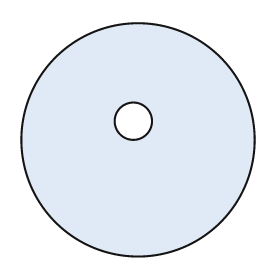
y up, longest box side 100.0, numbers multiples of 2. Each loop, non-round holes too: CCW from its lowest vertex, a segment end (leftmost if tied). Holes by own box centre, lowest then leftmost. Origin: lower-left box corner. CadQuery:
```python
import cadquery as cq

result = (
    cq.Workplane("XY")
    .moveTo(50.0, 50.0)
    .circle(50.0)
    .moveTo(48.0, 58.0)
    .circle(8.0)
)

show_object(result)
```